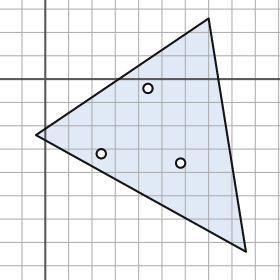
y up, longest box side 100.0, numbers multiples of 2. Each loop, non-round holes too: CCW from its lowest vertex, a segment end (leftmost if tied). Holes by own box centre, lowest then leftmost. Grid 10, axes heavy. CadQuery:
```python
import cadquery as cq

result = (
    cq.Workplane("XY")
    .moveTo(86.0, -74.0)
    .lineTo(70.0, 26.0)
    .lineTo(-4.0, -24.0)
    .close()
    .moveTo(58.0, -36.0)
    .circle(2.0)
    .moveTo(24.0, -32.0)
    .circle(2.0)
    .moveTo(44.0, -4.0)
    .circle(2.0)
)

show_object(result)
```